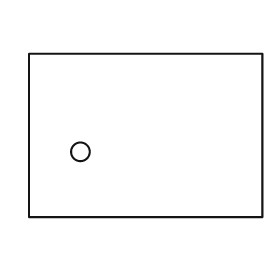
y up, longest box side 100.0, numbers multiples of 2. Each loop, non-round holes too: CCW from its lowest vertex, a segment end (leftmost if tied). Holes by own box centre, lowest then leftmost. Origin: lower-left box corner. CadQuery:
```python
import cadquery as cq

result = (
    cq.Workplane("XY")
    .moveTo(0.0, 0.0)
    .lineTo(100.0, 0.0)
    .lineTo(100.0, 70.0)
    .lineTo(0.0, 70.0)
    .close()
    .moveTo(22.0, 28.0)
    .circle(4.0)
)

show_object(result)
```